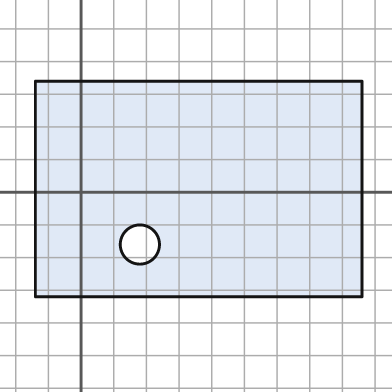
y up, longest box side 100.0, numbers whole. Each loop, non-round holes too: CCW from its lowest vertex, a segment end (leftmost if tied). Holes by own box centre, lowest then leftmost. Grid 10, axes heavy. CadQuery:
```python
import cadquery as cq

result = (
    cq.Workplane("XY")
    .moveTo(-14.0, -32.0)
    .lineTo(86.0, -32.0)
    .lineTo(86.0, 34.0)
    .lineTo(-14.0, 34.0)
    .close()
    .moveTo(18.0, -16.0)
    .circle(6.0)
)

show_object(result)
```